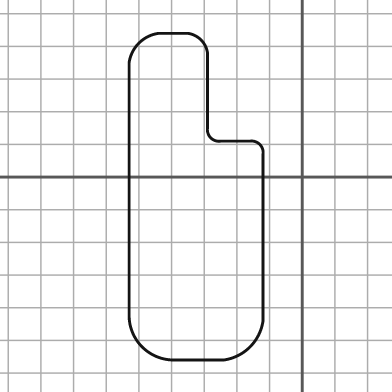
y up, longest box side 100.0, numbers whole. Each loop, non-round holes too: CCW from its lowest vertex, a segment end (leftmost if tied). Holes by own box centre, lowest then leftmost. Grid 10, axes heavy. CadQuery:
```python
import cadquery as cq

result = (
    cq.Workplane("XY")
    .moveTo(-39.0, -56.0)
    .lineTo(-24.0, -56.0)
    .threePointArc((-16.0, -52.0), (-12.0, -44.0))
    .lineTo(-12.0, 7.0)
    .threePointArc((-13.0, 10.0), (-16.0, 11.0))
    .lineTo(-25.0, 11.0)
    .threePointArc((-28.0, 12.0), (-29.0, 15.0))
    .lineTo(-29.0, 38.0)
    .threePointArc((-31.0, 42.0), (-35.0, 44.0))
    .lineTo(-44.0, 44.0)
    .threePointArc((-50.0, 41.0), (-53.0, 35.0))
    .lineTo(-53.0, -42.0)
    .threePointArc((-49.0, -52.0), (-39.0, -56.0))
    .close()
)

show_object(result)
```